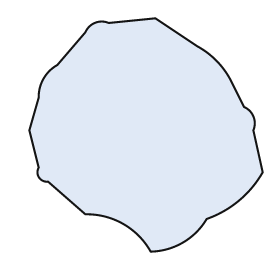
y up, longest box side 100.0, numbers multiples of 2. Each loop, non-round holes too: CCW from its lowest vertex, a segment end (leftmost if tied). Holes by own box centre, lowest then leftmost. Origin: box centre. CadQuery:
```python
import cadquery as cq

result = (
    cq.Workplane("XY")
    .moveTo(2.0, -50.0)
    .threePointArc((16.0, -46.0), (26.0, -36.0))
    .threePointArc((40.0, -28.0), (50.0, -16.0))
    .lineTo(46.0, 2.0)
    .threePointArc((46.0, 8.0), (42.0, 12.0))
    .lineTo(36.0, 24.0)
    .threePointArc((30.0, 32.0), (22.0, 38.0))
    .lineTo(4.0, 50.0)
    .lineTo(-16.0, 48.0)
    .threePointArc((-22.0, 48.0), (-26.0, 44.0))
    .lineTo(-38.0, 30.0)
    .threePointArc((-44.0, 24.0), (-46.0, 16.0))
    .lineTo(-50.0, 2.0)
    .lineTo(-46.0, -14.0)
    .threePointArc((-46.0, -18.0), (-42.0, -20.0))
    .lineTo(-26.0, -34.0)
    .threePointArc((-10.0, -38.0), (2.0, -50.0))
    .close()
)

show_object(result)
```